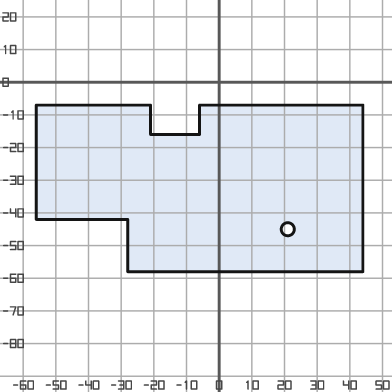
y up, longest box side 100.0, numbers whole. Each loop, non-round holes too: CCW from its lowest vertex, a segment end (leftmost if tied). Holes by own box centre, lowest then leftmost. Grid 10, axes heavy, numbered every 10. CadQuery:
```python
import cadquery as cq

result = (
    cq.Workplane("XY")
    .moveTo(-28.0, -58.0)
    .lineTo(44.0, -58.0)
    .lineTo(44.0, -7.0)
    .lineTo(-6.0, -7.0)
    .lineTo(-6.0, -16.0)
    .lineTo(-21.0, -16.0)
    .lineTo(-21.0, -7.0)
    .lineTo(-56.0, -7.0)
    .lineTo(-56.0, -42.0)
    .lineTo(-28.0, -42.0)
    .close()
    .moveTo(21.0, -45.0)
    .circle(2.0)
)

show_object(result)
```